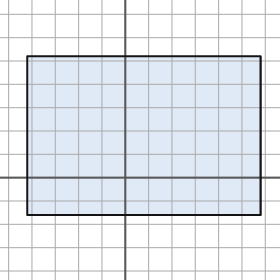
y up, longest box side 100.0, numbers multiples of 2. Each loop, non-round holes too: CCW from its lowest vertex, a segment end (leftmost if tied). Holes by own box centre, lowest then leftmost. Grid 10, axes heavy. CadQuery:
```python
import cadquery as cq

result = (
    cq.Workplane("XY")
    .moveTo(-42.0, -16.0)
    .lineTo(58.0, -16.0)
    .lineTo(58.0, 52.0)
    .lineTo(-42.0, 52.0)
    .close()
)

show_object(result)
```